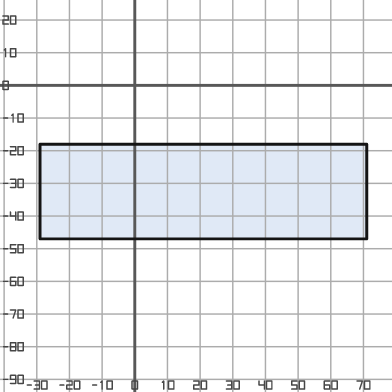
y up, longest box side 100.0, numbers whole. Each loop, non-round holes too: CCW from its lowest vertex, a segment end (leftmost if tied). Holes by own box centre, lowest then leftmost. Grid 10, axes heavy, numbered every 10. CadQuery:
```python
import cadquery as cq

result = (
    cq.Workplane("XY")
    .moveTo(-29.0, -47.0)
    .lineTo(71.0, -47.0)
    .lineTo(71.0, -18.0)
    .lineTo(-29.0, -18.0)
    .close()
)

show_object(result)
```